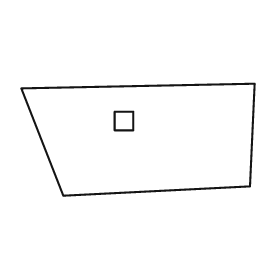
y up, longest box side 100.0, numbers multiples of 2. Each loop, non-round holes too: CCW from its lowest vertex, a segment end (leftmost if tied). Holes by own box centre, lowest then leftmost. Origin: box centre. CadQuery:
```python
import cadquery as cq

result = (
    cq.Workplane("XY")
    .moveTo(-32.0, -24.0)
    .lineTo(48.0, -20.0)
    .lineTo(50.0, 24.0)
    .lineTo(-50.0, 22.0)
    .close()
    .moveTo(-10.0, 4.0)
    .lineTo(-2.0, 4.0)
    .lineTo(-2.0, 12.0)
    .lineTo(-10.0, 12.0)
    .close()
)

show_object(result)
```